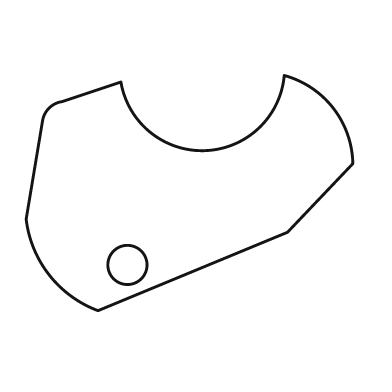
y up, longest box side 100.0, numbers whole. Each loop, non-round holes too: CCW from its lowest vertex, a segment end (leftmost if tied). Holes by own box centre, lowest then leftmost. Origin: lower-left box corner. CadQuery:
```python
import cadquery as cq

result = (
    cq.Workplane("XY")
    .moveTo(22.0, 0.0)
    .lineTo(80.0, 24.0)
    .lineTo(100.0, 45.0)
    .threePointArc((94.0, 62.0), (79.0, 72.0))
    .threePointArc((55.0, 49.0), (29.0, 70.0))
    .lineTo(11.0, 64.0)
    .threePointArc((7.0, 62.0), (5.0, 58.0))
    .lineTo(0.0, 28.0)
    .threePointArc((7.0, 11.0), (22.0, 0.0))
    .close()
    .moveTo(31.0, 14.0)
    .circle(6.0)
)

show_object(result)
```